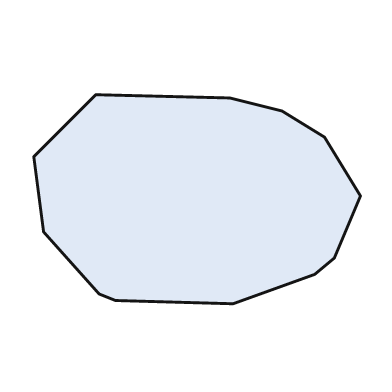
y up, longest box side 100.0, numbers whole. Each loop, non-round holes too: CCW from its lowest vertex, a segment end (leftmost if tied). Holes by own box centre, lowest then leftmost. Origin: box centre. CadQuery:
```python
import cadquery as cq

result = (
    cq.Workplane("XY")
    .moveTo(11.0, -32.0)
    .lineTo(36.0, -23.0)
    .lineTo(42.0, -18.0)
    .lineTo(50.0, 1.0)
    .lineTo(39.0, 19.0)
    .lineTo(26.0, 27.0)
    .lineTo(10.0, 31.0)
    .lineTo(-31.0, 32.0)
    .lineTo(-50.0, 13.0)
    .lineTo(-47.0, -10.0)
    .lineTo(-30.0, -29.0)
    .lineTo(-25.0, -31.0)
    .close()
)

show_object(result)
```